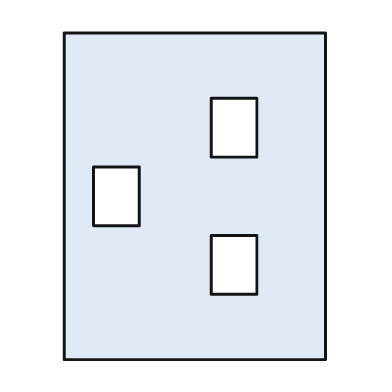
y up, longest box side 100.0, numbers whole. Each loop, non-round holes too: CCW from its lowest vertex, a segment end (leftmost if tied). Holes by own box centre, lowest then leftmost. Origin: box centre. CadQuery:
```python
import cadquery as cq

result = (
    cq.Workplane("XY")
    .moveTo(-40.0, -50.0)
    .lineTo(40.0, -50.0)
    .lineTo(40.0, 50.0)
    .lineTo(-40.0, 50.0)
    .close()
    .moveTo(5.0, -30.0)
    .lineTo(19.0, -30.0)
    .lineTo(19.0, -12.0)
    .lineTo(5.0, -12.0)
    .close()
    .moveTo(-31.0, -9.0)
    .lineTo(-17.0, -9.0)
    .lineTo(-17.0, 9.0)
    .lineTo(-31.0, 9.0)
    .close()
    .moveTo(5.0, 12.0)
    .lineTo(19.0, 12.0)
    .lineTo(19.0, 30.0)
    .lineTo(5.0, 30.0)
    .close()
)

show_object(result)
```